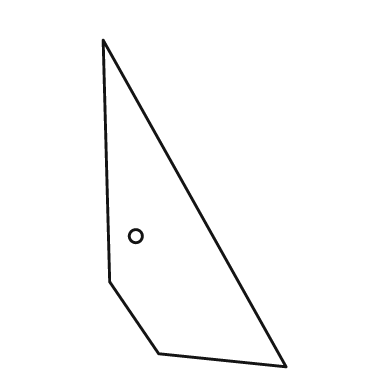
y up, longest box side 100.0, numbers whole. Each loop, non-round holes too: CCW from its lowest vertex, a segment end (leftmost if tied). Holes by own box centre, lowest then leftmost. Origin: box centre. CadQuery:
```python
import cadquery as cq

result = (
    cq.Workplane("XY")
    .moveTo(28.0, -50.0)
    .lineTo(-28.0, 50.0)
    .lineTo(-26.0, -24.0)
    .lineTo(-11.0, -46.0)
    .close()
    .moveTo(-18.0, -10.0)
    .circle(2.0)
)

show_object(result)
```